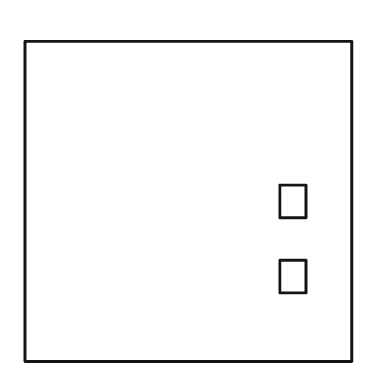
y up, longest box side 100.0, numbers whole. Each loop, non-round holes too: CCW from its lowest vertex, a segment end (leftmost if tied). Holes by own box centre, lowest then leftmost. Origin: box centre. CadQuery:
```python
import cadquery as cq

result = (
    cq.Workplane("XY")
    .moveTo(-50.0, -49.0)
    .lineTo(50.0, -49.0)
    .lineTo(50.0, 49.0)
    .lineTo(-50.0, 49.0)
    .close()
    .moveTo(28.0, -28.0)
    .lineTo(36.0, -28.0)
    .lineTo(36.0, -18.0)
    .lineTo(28.0, -18.0)
    .close()
    .moveTo(28.0, -5.0)
    .lineTo(36.0, -5.0)
    .lineTo(36.0, 5.0)
    .lineTo(28.0, 5.0)
    .close()
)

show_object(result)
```